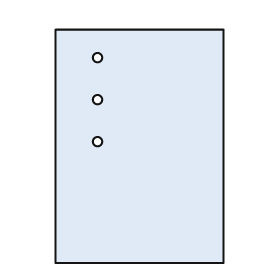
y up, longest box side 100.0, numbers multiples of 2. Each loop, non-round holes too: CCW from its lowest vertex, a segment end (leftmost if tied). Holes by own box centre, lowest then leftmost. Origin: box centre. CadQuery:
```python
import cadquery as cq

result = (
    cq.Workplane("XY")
    .moveTo(-36.0, -50.0)
    .lineTo(36.0, -50.0)
    .lineTo(36.0, 50.0)
    .lineTo(-36.0, 50.0)
    .close()
    .moveTo(-18.0, 2.0)
    .circle(2.0)
    .moveTo(-18.0, 20.0)
    .circle(2.0)
    .moveTo(-18.0, 38.0)
    .circle(2.0)
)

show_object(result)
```